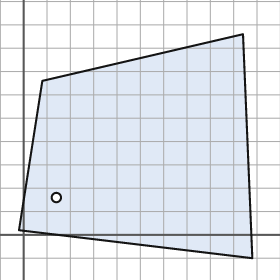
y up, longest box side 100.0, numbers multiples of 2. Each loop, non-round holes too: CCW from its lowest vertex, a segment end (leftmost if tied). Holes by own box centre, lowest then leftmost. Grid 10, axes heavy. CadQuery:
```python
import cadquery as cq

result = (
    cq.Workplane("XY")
    .moveTo(98.0, -10.0)
    .lineTo(94.0, 86.0)
    .lineTo(8.0, 66.0)
    .lineTo(-2.0, 2.0)
    .close()
    .moveTo(14.0, 16.0)
    .circle(2.0)
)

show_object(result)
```